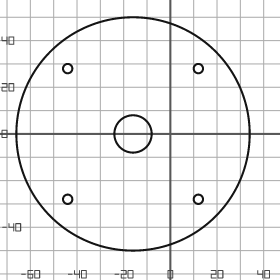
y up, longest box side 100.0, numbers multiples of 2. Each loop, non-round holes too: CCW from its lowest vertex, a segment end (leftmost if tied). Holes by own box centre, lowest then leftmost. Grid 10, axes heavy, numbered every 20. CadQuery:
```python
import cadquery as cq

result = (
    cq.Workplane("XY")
    .moveTo(-16.0, 0.0)
    .circle(50.0)
    .moveTo(-44.0, -28.0)
    .circle(2.0)
    .moveTo(12.0, -28.0)
    .circle(2.0)
    .moveTo(-16.0, 0.0)
    .circle(8.0)
    .moveTo(-44.0, 28.0)
    .circle(2.0)
    .moveTo(12.0, 28.0)
    .circle(2.0)
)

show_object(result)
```